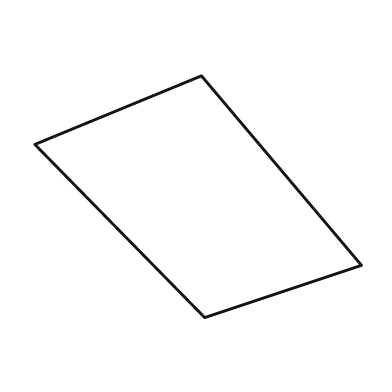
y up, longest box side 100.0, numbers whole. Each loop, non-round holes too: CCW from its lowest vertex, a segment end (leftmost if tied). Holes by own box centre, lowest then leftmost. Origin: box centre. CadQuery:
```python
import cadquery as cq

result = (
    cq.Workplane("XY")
    .moveTo(2.0, -37.0)
    .lineTo(50.0, -21.0)
    .lineTo(1.0, 37.0)
    .lineTo(-50.0, 16.0)
    .close()
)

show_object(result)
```